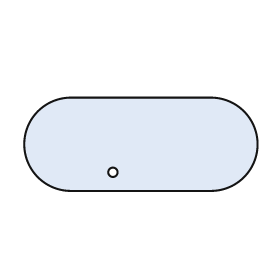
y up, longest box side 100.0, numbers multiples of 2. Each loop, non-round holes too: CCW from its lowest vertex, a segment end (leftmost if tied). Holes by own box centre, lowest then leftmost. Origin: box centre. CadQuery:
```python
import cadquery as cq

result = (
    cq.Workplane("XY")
    .moveTo(-30.0, -20.0)
    .lineTo(30.0, -20.0)
    .threePointArc((50.0, 0.0), (30.0, 20.0))
    .lineTo(-30.0, 20.0)
    .threePointArc((-50.0, 0.0), (-30.0, -20.0))
    .close()
    .moveTo(-12.0, -12.0)
    .circle(2.0)
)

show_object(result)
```